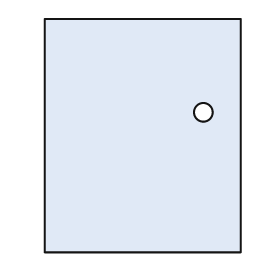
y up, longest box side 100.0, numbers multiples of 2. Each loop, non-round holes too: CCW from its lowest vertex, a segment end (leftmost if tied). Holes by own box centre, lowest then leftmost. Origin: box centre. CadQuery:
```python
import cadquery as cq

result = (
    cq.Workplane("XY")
    .moveTo(-42.0, -50.0)
    .lineTo(42.0, -50.0)
    .lineTo(42.0, 50.0)
    .lineTo(-42.0, 50.0)
    .close()
    .moveTo(26.0, 10.0)
    .circle(4.0)
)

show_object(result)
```